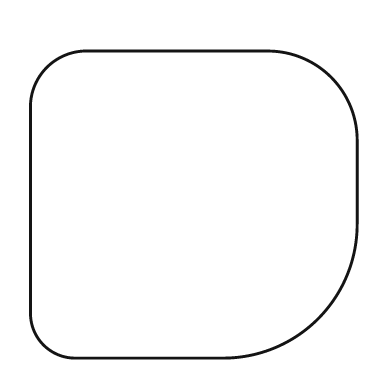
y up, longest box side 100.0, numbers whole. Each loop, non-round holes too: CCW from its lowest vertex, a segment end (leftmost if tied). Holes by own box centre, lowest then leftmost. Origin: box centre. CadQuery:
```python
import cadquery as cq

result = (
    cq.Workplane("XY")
    .moveTo(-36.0, -47.0)
    .lineTo(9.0, -47.0)
    .threePointArc((38.0, -35.0), (50.0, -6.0))
    .lineTo(50.0, 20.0)
    .threePointArc((42.0, 39.0), (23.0, 47.0))
    .lineTo(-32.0, 47.0)
    .threePointArc((-45.0, 42.0), (-50.0, 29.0))
    .lineTo(-50.0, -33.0)
    .threePointArc((-46.0, -43.0), (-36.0, -47.0))
    .close()
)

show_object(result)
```